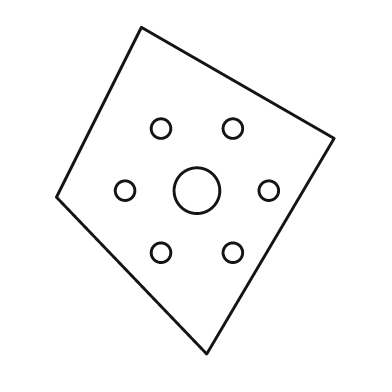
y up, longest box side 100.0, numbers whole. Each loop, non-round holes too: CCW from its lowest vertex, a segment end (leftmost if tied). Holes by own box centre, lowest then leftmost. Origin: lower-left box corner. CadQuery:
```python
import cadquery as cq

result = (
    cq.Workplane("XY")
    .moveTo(46.0, 0.0)
    .lineTo(85.0, 66.0)
    .lineTo(26.0, 100.0)
    .lineTo(0.0, 48.0)
    .close()
    .moveTo(32.0, 31.0)
    .circle(3.0)
    .moveTo(54.0, 31.0)
    .circle(3.0)
    .moveTo(21.0, 50.0)
    .circle(3.0)
    .moveTo(43.0, 50.0)
    .circle(7.0)
    .moveTo(65.0, 50.0)
    .circle(3.0)
    .moveTo(32.0, 69.0)
    .circle(3.0)
    .moveTo(54.0, 69.0)
    .circle(3.0)
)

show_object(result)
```